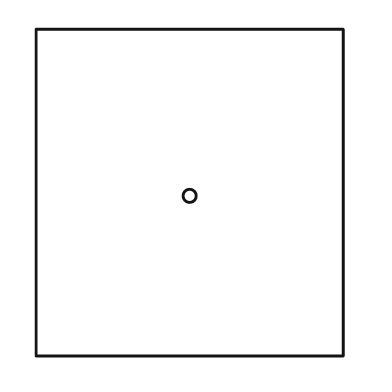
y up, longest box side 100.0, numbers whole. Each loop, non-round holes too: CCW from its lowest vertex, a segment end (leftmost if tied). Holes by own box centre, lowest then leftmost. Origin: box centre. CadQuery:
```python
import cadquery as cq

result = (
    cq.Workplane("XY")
    .moveTo(-47.0, -50.0)
    .lineTo(47.0, -50.0)
    .lineTo(47.0, 50.0)
    .lineTo(-47.0, 50.0)
    .close()
    .moveTo(0.0, -1.0)
    .circle(2.0)
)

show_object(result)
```